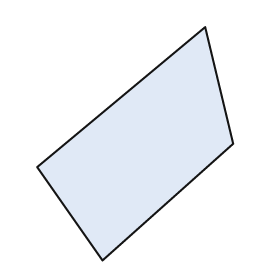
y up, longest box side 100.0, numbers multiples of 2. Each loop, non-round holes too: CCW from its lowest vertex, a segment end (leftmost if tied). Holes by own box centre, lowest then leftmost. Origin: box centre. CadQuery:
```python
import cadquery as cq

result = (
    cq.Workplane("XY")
    .moveTo(-14.0, -50.0)
    .lineTo(42.0, 0.0)
    .lineTo(30.0, 50.0)
    .lineTo(-42.0, -10.0)
    .close()
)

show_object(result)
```